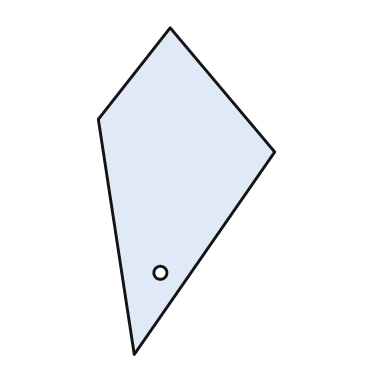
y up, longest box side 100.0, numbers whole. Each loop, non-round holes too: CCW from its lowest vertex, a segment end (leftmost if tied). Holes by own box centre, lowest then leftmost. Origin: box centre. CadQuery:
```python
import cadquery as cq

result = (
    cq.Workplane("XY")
    .moveTo(-16.0, -50.0)
    .lineTo(27.0, 12.0)
    .lineTo(-5.0, 50.0)
    .lineTo(-27.0, 22.0)
    .close()
    .moveTo(-8.0, -25.0)
    .circle(2.0)
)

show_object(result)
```